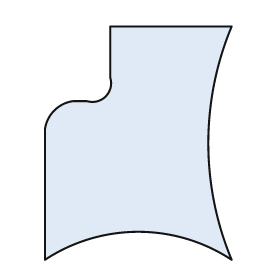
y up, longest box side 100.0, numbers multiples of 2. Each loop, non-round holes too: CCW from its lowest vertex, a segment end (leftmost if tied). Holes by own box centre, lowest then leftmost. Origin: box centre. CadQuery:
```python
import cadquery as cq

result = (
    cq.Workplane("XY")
    .moveTo(-40.0, -50.0)
    .threePointArc((0.0, -38.0), (40.0, -50.0))
    .threePointArc((30.0, 0.0), (40.0, 50.0))
    .lineTo(-12.0, 50.0)
    .lineTo(-12.0, 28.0)
    .threePointArc((-14.0, 20.0), (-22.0, 18.0))
    .lineTo(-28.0, 18.0)
    .threePointArc((-36.0, 14.0), (-40.0, 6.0))
    .close()
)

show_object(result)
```